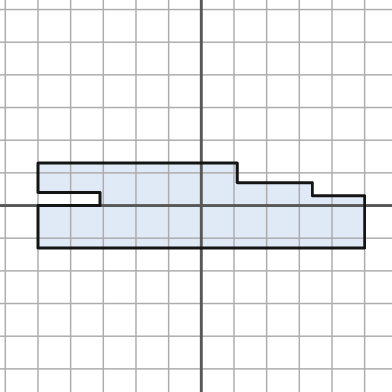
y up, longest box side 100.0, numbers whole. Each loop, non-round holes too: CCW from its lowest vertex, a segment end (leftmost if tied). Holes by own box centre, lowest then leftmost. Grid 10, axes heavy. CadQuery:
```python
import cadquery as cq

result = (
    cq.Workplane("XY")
    .moveTo(-50.0, -13.0)
    .lineTo(50.0, -13.0)
    .lineTo(50.0, 3.0)
    .lineTo(34.0, 3.0)
    .lineTo(34.0, 7.0)
    .lineTo(11.0, 7.0)
    .lineTo(11.0, 13.0)
    .lineTo(-50.0, 13.0)
    .lineTo(-50.0, 4.0)
    .lineTo(-31.0, 4.0)
    .lineTo(-31.0, 0.0)
    .lineTo(-50.0, 0.0)
    .close()
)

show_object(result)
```